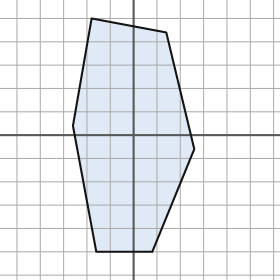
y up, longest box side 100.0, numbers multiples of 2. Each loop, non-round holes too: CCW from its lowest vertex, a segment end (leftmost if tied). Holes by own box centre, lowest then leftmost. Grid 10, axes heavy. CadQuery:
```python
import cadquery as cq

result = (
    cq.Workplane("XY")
    .moveTo(-16.0, -50.0)
    .lineTo(8.0, -50.0)
    .lineTo(26.0, -6.0)
    .lineTo(14.0, 44.0)
    .lineTo(-18.0, 50.0)
    .lineTo(-26.0, 4.0)
    .close()
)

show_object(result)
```